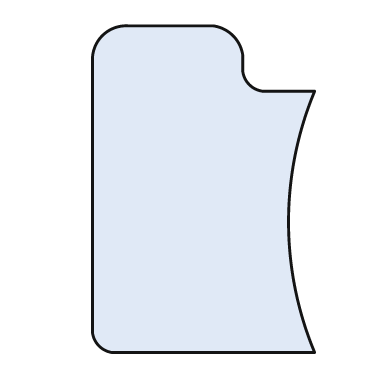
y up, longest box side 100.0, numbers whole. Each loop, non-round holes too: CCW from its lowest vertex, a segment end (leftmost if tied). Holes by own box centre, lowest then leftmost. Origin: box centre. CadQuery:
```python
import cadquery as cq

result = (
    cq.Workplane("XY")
    .moveTo(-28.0, -50.0)
    .lineTo(34.0, -50.0)
    .threePointArc((26.0, -10.0), (34.0, 30.0))
    .lineTo(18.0, 30.0)
    .threePointArc((14.0, 32.0), (12.0, 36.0))
    .lineTo(12.0, 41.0)
    .threePointArc((9.0, 47.0), (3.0, 50.0))
    .lineTo(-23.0, 50.0)
    .threePointArc((-31.0, 47.0), (-34.0, 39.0))
    .lineTo(-34.0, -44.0)
    .threePointArc((-32.0, -48.0), (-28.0, -50.0))
    .close()
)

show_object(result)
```